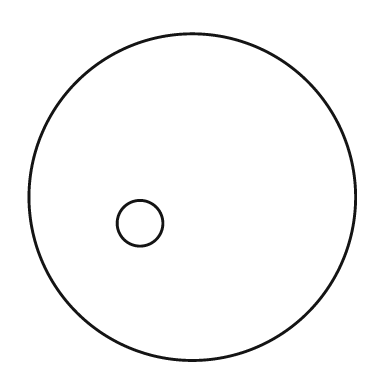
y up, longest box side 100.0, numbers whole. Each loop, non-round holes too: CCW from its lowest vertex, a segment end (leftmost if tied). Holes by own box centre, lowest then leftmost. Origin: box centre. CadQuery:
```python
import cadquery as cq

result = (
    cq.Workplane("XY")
    .moveTo(0.0, 0.0)
    .circle(50.0)
    .moveTo(-16.0, -8.0)
    .circle(7.0)
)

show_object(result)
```